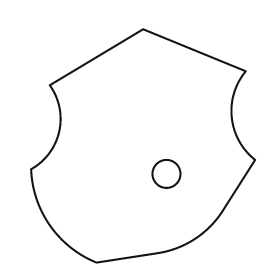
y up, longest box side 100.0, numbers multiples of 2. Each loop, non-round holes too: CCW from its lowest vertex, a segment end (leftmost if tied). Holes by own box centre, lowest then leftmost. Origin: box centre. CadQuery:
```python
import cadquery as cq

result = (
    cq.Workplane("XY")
    .moveTo(-20.0, -50.0)
    .lineTo(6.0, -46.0)
    .threePointArc((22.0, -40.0), (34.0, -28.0))
    .lineTo(48.0, -6.0)
    .threePointArc((38.0, 12.0), (44.0, 32.0))
    .lineTo(0.0, 50.0)
    .lineTo(-40.0, 26.0)
    .threePointArc((-36.0, 6.0), (-48.0, -10.0))
    .threePointArc((-40.0, -34.0), (-20.0, -50.0))
    .close()
    .moveTo(10.0, -12.0)
    .circle(6.0)
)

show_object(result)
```